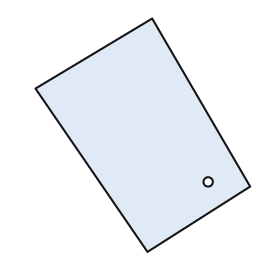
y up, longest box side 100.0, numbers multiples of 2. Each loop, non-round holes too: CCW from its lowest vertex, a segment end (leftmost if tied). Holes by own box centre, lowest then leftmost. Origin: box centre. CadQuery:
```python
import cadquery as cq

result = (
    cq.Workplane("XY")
    .moveTo(2.0, -50.0)
    .lineTo(46.0, -22.0)
    .lineTo(4.0, 50.0)
    .lineTo(-46.0, 20.0)
    .close()
    .moveTo(28.0, -20.0)
    .circle(2.0)
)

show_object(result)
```